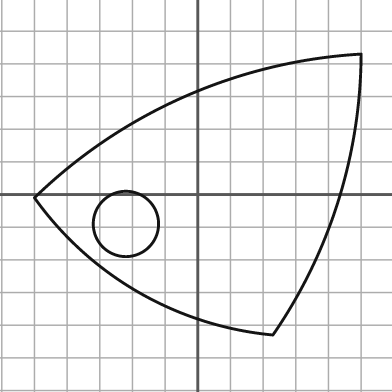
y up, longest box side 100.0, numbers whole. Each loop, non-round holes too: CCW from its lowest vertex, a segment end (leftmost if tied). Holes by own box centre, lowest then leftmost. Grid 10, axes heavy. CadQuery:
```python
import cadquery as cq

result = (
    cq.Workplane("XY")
    .moveTo(23.0, -43.0)
    .threePointArc((43.0, -2.0), (50.0, 43.0))
    .threePointArc((-4.0, 30.0), (-50.0, -1.0))
    .threePointArc((-18.0, -30.0), (23.0, -43.0))
    .close()
    .moveTo(-22.0, -9.0)
    .circle(10.0)
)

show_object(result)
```